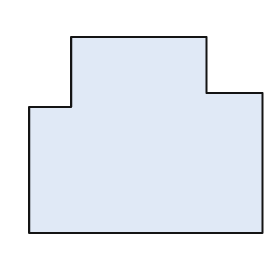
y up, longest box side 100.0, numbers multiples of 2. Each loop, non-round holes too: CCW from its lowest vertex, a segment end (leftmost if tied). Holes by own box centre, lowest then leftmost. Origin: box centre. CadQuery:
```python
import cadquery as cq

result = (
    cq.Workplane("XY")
    .moveTo(-50.0, -42.0)
    .lineTo(50.0, -42.0)
    .lineTo(50.0, 18.0)
    .lineTo(26.0, 18.0)
    .lineTo(26.0, 42.0)
    .lineTo(-32.0, 42.0)
    .lineTo(-32.0, 12.0)
    .lineTo(-50.0, 12.0)
    .close()
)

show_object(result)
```